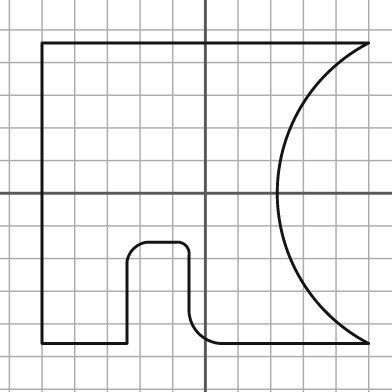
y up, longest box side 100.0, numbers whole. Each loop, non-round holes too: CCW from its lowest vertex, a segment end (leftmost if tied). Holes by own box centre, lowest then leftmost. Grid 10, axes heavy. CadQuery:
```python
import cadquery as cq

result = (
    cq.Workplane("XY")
    .moveTo(-50.0, -46.0)
    .lineTo(-24.0, -46.0)
    .lineTo(-24.0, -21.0)
    .threePointArc((-22.0, -17.0), (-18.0, -15.0))
    .lineTo(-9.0, -15.0)
    .threePointArc((-6.0, -16.0), (-5.0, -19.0))
    .lineTo(-5.0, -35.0)
    .threePointArc((-2.0, -43.0), (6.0, -46.0))
    .lineTo(50.0, -46.0)
    .threePointArc((22.0, 0.0), (50.0, 46.0))
    .lineTo(-50.0, 46.0)
    .close()
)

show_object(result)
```